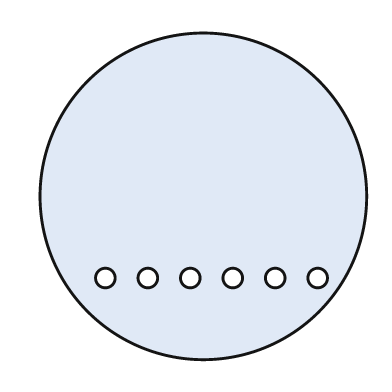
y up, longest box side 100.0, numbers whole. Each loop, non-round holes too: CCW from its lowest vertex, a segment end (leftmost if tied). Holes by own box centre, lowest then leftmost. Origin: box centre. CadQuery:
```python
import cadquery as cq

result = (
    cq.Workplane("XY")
    .moveTo(0.0, 0.0)
    .circle(50.0)
    .moveTo(-30.0, -25.0)
    .circle(3.0)
    .moveTo(-17.0, -25.0)
    .circle(3.0)
    .moveTo(-4.0, -25.0)
    .circle(3.0)
    .moveTo(9.0, -25.0)
    .circle(3.0)
    .moveTo(22.0, -25.0)
    .circle(3.0)
    .moveTo(35.0, -25.0)
    .circle(3.0)
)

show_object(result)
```